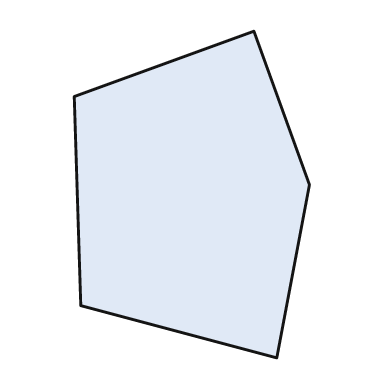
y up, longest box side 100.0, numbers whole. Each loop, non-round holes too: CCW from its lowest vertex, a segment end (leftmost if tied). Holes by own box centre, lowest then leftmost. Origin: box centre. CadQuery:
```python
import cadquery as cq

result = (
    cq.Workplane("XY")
    .moveTo(26.0, -50.0)
    .lineTo(36.0, 3.0)
    .lineTo(19.0, 50.0)
    .lineTo(-36.0, 30.0)
    .lineTo(-34.0, -34.0)
    .close()
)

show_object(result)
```